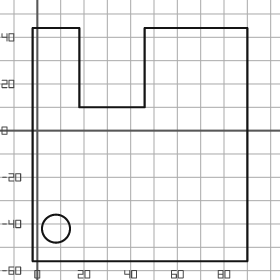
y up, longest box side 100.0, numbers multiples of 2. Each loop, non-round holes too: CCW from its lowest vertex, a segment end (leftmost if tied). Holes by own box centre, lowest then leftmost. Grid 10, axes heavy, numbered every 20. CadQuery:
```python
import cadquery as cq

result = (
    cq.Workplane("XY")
    .moveTo(-2.0, -56.0)
    .lineTo(90.0, -56.0)
    .lineTo(90.0, 44.0)
    .lineTo(46.0, 44.0)
    .lineTo(46.0, 10.0)
    .lineTo(18.0, 10.0)
    .lineTo(18.0, 44.0)
    .lineTo(-2.0, 44.0)
    .close()
    .moveTo(8.0, -42.0)
    .circle(6.0)
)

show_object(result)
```